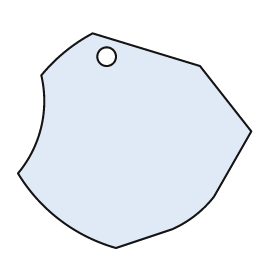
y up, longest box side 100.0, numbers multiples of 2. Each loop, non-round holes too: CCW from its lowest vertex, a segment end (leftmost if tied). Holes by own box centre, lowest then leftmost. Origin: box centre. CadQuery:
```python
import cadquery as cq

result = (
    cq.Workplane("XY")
    .moveTo(-8.0, -46.0)
    .lineTo(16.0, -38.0)
    .threePointArc((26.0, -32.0), (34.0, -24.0))
    .lineTo(50.0, 4.0)
    .lineTo(28.0, 32.0)
    .lineTo(-18.0, 46.0)
    .threePointArc((-30.0, 38.0), (-40.0, 28.0))
    .threePointArc((-40.0, 6.0), (-50.0, -14.0))
    .threePointArc((-32.0, -34.0), (-8.0, -46.0))
    .close()
    .moveTo(-12.0, 36.0)
    .circle(4.0)
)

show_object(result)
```